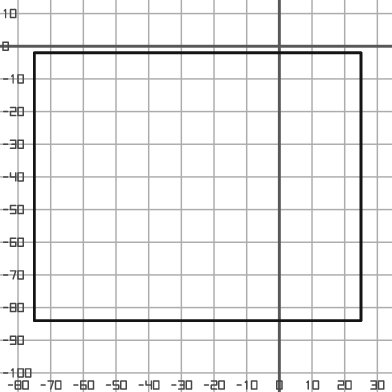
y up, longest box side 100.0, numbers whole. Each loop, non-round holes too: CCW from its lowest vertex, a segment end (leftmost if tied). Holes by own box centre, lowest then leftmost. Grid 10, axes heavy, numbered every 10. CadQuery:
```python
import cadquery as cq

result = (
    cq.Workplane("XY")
    .moveTo(-75.0, -84.0)
    .lineTo(25.0, -84.0)
    .lineTo(25.0, -2.0)
    .lineTo(-75.0, -2.0)
    .close()
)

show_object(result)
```